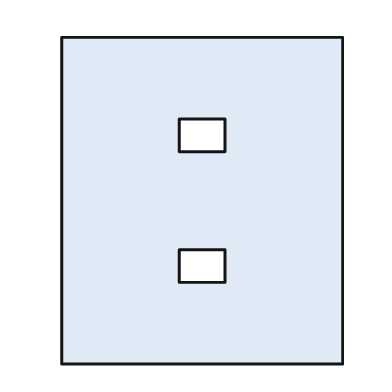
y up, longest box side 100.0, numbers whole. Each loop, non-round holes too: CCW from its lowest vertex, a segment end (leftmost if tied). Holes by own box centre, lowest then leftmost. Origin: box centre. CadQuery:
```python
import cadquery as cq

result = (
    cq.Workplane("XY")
    .moveTo(-43.0, -50.0)
    .lineTo(43.0, -50.0)
    .lineTo(43.0, 50.0)
    .lineTo(-43.0, 50.0)
    .close()
    .moveTo(-7.0, -25.0)
    .lineTo(7.0, -25.0)
    .lineTo(7.0, -15.0)
    .lineTo(-7.0, -15.0)
    .close()
    .moveTo(-7.0, 15.0)
    .lineTo(7.0, 15.0)
    .lineTo(7.0, 25.0)
    .lineTo(-7.0, 25.0)
    .close()
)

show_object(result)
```